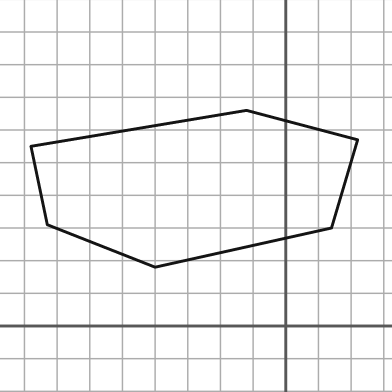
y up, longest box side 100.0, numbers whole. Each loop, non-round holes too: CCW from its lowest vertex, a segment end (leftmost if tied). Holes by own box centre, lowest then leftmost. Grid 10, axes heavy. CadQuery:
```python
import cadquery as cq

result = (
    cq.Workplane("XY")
    .moveTo(-40.0, 18.0)
    .lineTo(14.0, 30.0)
    .lineTo(22.0, 57.0)
    .lineTo(-12.0, 66.0)
    .lineTo(-78.0, 55.0)
    .lineTo(-73.0, 31.0)
    .close()
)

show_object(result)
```